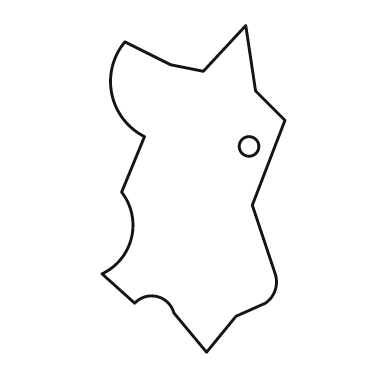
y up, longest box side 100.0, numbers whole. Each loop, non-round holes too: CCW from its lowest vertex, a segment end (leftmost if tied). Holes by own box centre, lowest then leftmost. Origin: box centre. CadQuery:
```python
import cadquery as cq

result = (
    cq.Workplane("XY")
    .moveTo(4.0, -50.0)
    .lineTo(13.0, -39.0)
    .lineTo(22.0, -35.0)
    .threePointArc((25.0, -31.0), (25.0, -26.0))
    .lineTo(18.0, -5.0)
    .lineTo(28.0, 21.0)
    .lineTo(19.0, 30.0)
    .lineTo(16.0, 50.0)
    .lineTo(3.0, 36.0)
    .lineTo(-7.0, 38.0)
    .lineTo(-21.0, 45.0)
    .threePointArc((-25.0, 29.0), (-15.0, 16.0))
    .lineTo(-22.0, -1.0)
    .threePointArc((-19.0, -15.0), (-28.0, -26.0))
    .lineTo(-18.0, -35.0)
    .threePointArc((-11.0, -33.0), (-6.0, -38.0))
    .close()
    .moveTo(17.0, 13.0)
    .circle(3.0)
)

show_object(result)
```